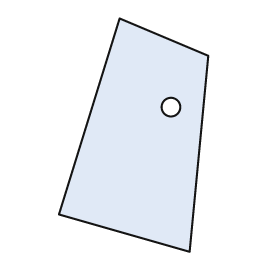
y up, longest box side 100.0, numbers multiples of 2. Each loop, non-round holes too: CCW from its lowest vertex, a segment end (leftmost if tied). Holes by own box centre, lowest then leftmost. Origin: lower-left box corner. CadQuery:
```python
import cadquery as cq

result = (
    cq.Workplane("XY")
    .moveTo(56.0, 0.0)
    .lineTo(64.0, 84.0)
    .lineTo(26.0, 100.0)
    .lineTo(0.0, 16.0)
    .close()
    .moveTo(48.0, 62.0)
    .circle(4.0)
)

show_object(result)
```